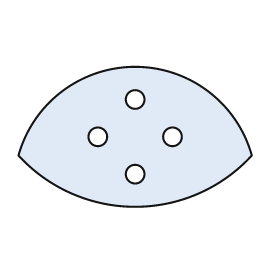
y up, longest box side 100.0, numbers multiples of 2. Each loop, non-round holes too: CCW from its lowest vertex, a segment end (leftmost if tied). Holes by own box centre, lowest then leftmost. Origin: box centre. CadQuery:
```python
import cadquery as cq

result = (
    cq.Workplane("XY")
    .moveTo(-50.0, -8.0)
    .threePointArc((0.0, -30.0), (50.0, -8.0))
    .threePointArc((0.0, 30.0), (-50.0, -8.0))
    .close()
    .moveTo(0.0, -16.0)
    .circle(4.0)
    .moveTo(-16.0, 0.0)
    .circle(4.0)
    .moveTo(16.0, 0.0)
    .circle(4.0)
    .moveTo(0.0, 16.0)
    .circle(4.0)
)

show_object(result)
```